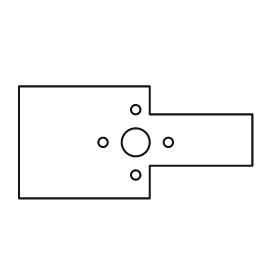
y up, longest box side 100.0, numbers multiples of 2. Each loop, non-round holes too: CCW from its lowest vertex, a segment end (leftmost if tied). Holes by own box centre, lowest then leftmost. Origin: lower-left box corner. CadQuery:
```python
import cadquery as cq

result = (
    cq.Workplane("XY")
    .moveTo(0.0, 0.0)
    .lineTo(56.0, 0.0)
    .lineTo(56.0, 14.0)
    .lineTo(100.0, 14.0)
    .lineTo(100.0, 36.0)
    .lineTo(56.0, 36.0)
    .lineTo(56.0, 48.0)
    .lineTo(0.0, 48.0)
    .close()
    .moveTo(50.0, 10.0)
    .circle(2.0)
    .moveTo(36.0, 24.0)
    .circle(2.0)
    .moveTo(50.0, 24.0)
    .circle(6.0)
    .moveTo(64.0, 24.0)
    .circle(2.0)
    .moveTo(50.0, 38.0)
    .circle(2.0)
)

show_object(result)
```